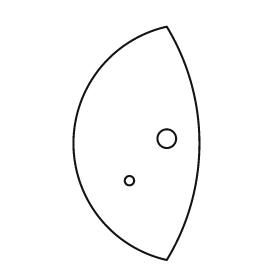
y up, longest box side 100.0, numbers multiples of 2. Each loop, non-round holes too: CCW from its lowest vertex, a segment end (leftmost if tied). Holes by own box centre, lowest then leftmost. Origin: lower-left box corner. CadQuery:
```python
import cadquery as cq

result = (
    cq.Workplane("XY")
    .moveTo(40.0, 0.0)
    .threePointArc((54.0, 50.0), (40.0, 100.0))
    .threePointArc((0.0, 50.0), (40.0, 0.0))
    .close()
    .moveTo(24.0, 34.0)
    .circle(2.0)
    .moveTo(40.0, 52.0)
    .circle(4.0)
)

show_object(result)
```